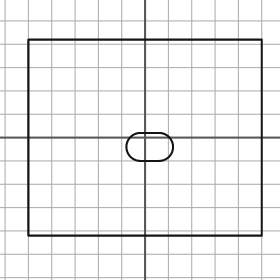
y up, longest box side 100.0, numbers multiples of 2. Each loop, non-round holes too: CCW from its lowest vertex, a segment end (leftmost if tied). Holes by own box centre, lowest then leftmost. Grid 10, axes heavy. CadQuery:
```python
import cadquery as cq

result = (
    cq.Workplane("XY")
    .moveTo(-50.0, -42.0)
    .lineTo(50.0, -42.0)
    .lineTo(50.0, 42.0)
    .lineTo(-50.0, 42.0)
    .close()
    .moveTo(-2.0, -10.0)
    .lineTo(6.0, -10.0)
    .threePointArc((12.0, -4.0), (6.0, 2.0))
    .lineTo(-2.0, 2.0)
    .threePointArc((-8.0, -4.0), (-2.0, -10.0))
    .close()
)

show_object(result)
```